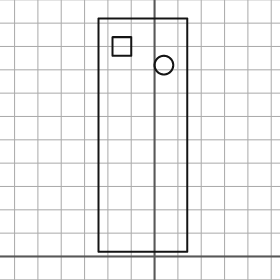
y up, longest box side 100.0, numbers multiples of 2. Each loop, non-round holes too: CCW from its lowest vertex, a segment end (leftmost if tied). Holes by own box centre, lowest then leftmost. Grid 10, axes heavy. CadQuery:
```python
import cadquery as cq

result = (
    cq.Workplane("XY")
    .moveTo(-24.0, 2.0)
    .lineTo(14.0, 2.0)
    .lineTo(14.0, 102.0)
    .lineTo(-24.0, 102.0)
    .close()
    .moveTo(4.0, 82.0)
    .circle(4.0)
    .moveTo(-18.0, 86.0)
    .lineTo(-10.0, 86.0)
    .lineTo(-10.0, 94.0)
    .lineTo(-18.0, 94.0)
    .close()
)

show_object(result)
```